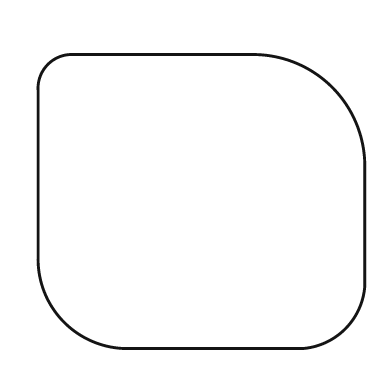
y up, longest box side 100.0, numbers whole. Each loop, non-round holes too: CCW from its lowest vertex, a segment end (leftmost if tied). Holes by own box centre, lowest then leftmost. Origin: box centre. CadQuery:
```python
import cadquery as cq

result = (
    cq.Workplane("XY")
    .moveTo(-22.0, -45.0)
    .lineTo(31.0, -45.0)
    .threePointArc((44.0, -39.0), (50.0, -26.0))
    .lineTo(50.0, 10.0)
    .threePointArc((40.0, 35.0), (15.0, 45.0))
    .lineTo(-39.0, 45.0)
    .threePointArc((-47.0, 42.0), (-50.0, 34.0))
    .lineTo(-50.0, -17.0)
    .threePointArc((-42.0, -37.0), (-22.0, -45.0))
    .close()
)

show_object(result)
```